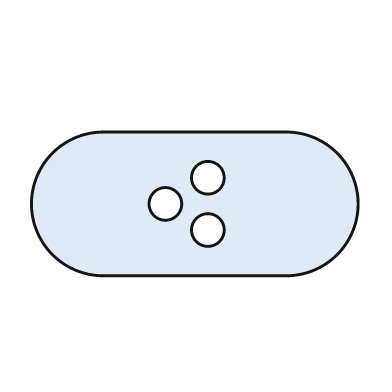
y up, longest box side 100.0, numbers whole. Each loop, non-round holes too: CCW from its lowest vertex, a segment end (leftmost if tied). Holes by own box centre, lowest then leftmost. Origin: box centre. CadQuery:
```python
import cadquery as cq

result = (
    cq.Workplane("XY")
    .moveTo(-28.0, -22.0)
    .lineTo(28.0, -22.0)
    .threePointArc((50.0, 0.0), (28.0, 22.0))
    .lineTo(-28.0, 22.0)
    .threePointArc((-50.0, 0.0), (-28.0, -22.0))
    .close()
    .moveTo(4.0, -8.0)
    .circle(5.0)
    .moveTo(-9.0, 0.0)
    .circle(5.0)
    .moveTo(4.0, 8.0)
    .circle(5.0)
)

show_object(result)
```